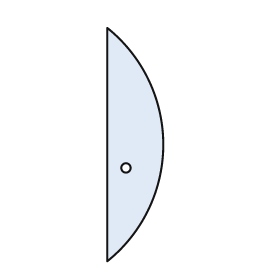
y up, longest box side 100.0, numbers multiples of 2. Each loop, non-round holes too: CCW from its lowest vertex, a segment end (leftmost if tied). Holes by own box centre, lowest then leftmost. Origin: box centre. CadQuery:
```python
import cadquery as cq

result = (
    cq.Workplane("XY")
    .moveTo(-12.0, -50.0)
    .threePointArc((12.0, 0.0), (-12.0, 50.0))
    .close()
    .moveTo(-4.0, -10.0)
    .circle(2.0)
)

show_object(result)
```